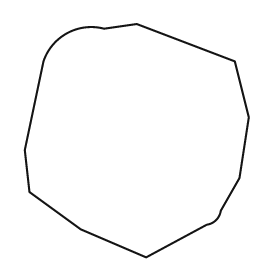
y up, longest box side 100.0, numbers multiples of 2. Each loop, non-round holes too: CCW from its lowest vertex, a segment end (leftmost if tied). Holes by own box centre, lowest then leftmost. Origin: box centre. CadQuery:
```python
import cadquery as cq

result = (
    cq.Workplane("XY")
    .moveTo(4.0, -50.0)
    .lineTo(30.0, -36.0)
    .threePointArc((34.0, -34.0), (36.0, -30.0))
    .lineTo(44.0, -16.0)
    .lineTo(48.0, 10.0)
    .lineTo(42.0, 34.0)
    .lineTo(0.0, 50.0)
    .lineTo(-14.0, 48.0)
    .threePointArc((-30.0, 46.0), (-40.0, 34.0))
    .lineTo(-48.0, -4.0)
    .lineTo(-46.0, -22.0)
    .lineTo(-24.0, -38.0)
    .close()
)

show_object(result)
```